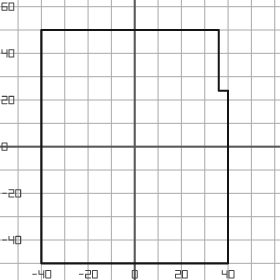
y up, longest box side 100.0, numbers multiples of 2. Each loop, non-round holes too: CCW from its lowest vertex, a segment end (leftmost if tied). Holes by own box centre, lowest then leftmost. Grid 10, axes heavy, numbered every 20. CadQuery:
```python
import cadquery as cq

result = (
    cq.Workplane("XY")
    .moveTo(-40.0, -50.0)
    .lineTo(40.0, -50.0)
    .lineTo(40.0, 24.0)
    .lineTo(36.0, 24.0)
    .lineTo(36.0, 50.0)
    .lineTo(-40.0, 50.0)
    .close()
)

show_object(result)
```